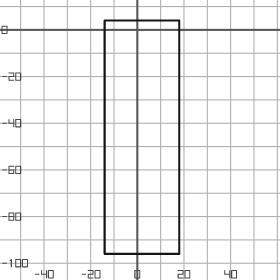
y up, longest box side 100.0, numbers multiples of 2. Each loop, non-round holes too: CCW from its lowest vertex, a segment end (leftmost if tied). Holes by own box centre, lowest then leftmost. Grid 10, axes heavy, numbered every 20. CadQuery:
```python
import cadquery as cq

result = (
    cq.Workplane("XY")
    .moveTo(-14.0, -96.0)
    .lineTo(18.0, -96.0)
    .lineTo(18.0, 4.0)
    .lineTo(-14.0, 4.0)
    .close()
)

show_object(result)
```